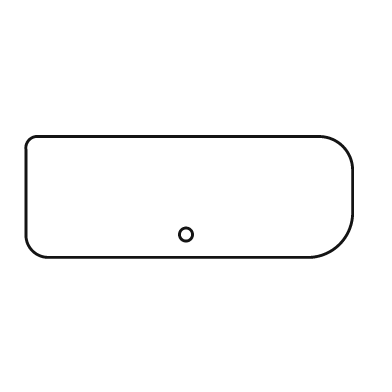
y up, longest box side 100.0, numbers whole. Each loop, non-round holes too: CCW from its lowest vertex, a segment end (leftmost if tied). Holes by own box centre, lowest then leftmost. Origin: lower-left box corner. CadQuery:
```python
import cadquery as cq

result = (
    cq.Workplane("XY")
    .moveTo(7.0, 0.0)
    .lineTo(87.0, 0.0)
    .threePointArc((96.0, 4.0), (100.0, 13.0))
    .lineTo(100.0, 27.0)
    .threePointArc((97.0, 34.0), (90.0, 37.0))
    .lineTo(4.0, 37.0)
    .threePointArc((1.0, 36.0), (0.0, 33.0))
    .lineTo(0.0, 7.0)
    .threePointArc((2.0, 2.0), (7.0, 0.0))
    .close()
    .moveTo(49.0, 7.0)
    .circle(2.0)
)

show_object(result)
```